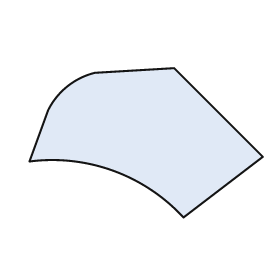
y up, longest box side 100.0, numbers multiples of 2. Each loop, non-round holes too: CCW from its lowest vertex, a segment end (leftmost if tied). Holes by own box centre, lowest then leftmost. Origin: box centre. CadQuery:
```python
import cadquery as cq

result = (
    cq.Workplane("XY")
    .moveTo(16.0, -32.0)
    .lineTo(50.0, -6.0)
    .lineTo(12.0, 32.0)
    .lineTo(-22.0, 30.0)
    .threePointArc((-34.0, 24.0), (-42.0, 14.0))
    .lineTo(-50.0, -8.0)
    .threePointArc((-14.0, -12.0), (16.0, -32.0))
    .close()
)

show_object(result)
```